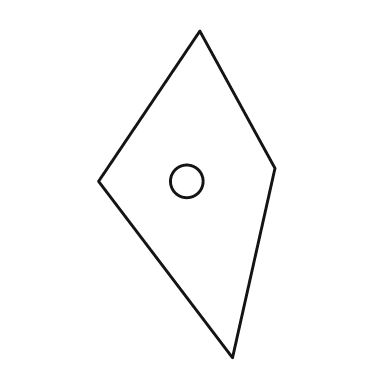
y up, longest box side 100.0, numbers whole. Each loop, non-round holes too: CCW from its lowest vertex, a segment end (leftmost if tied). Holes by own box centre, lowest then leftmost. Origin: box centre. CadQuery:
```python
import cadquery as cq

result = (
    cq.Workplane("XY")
    .moveTo(14.0, -50.0)
    .lineTo(27.0, 8.0)
    .lineTo(4.0, 50.0)
    .lineTo(-27.0, 4.0)
    .close()
    .moveTo(0.0, 4.0)
    .circle(5.0)
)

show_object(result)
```